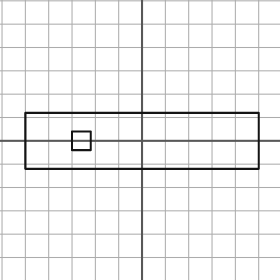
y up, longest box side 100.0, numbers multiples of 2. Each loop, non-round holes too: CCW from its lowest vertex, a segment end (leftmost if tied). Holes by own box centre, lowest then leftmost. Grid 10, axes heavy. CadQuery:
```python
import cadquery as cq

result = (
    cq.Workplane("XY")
    .moveTo(-50.0, -12.0)
    .lineTo(50.0, -12.0)
    .lineTo(50.0, 12.0)
    .lineTo(-50.0, 12.0)
    .close()
    .moveTo(-30.0, -4.0)
    .lineTo(-22.0, -4.0)
    .lineTo(-22.0, 4.0)
    .lineTo(-30.0, 4.0)
    .close()
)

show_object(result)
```